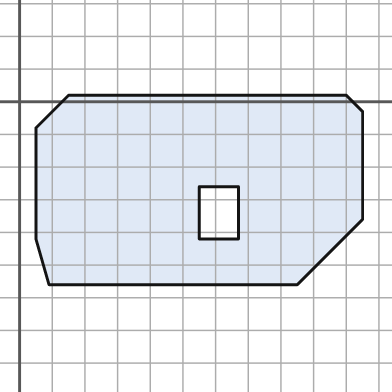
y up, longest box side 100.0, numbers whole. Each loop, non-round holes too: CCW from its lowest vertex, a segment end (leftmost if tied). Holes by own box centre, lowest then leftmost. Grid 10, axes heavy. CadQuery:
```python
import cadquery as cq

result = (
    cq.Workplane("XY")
    .moveTo(9.0, -56.0)
    .lineTo(85.0, -56.0)
    .lineTo(105.0, -36.0)
    .lineTo(105.0, -3.0)
    .lineTo(100.0, 2.0)
    .lineTo(15.0, 2.0)
    .lineTo(5.0, -8.0)
    .lineTo(5.0, -42.0)
    .close()
    .moveTo(55.0, -42.0)
    .lineTo(67.0, -42.0)
    .lineTo(67.0, -26.0)
    .lineTo(55.0, -26.0)
    .close()
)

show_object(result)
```